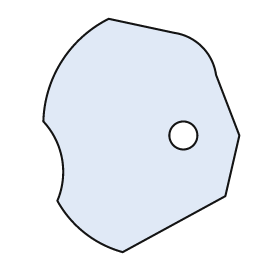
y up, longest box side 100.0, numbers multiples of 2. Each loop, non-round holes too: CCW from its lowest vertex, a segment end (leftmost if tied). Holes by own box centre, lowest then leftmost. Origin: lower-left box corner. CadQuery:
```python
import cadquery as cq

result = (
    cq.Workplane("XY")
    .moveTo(34.0, 0.0)
    .lineTo(78.0, 24.0)
    .lineTo(84.0, 50.0)
    .lineTo(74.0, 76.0)
    .threePointArc((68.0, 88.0), (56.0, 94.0))
    .lineTo(28.0, 100.0)
    .threePointArc((8.0, 82.0), (0.0, 56.0))
    .threePointArc((8.0, 40.0), (6.0, 22.0))
    .threePointArc((18.0, 8.0), (34.0, 0.0))
    .close()
    .moveTo(60.0, 50.0)
    .circle(6.0)
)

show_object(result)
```